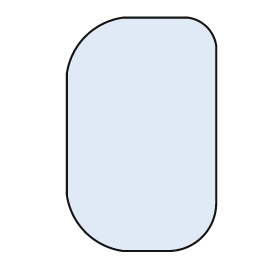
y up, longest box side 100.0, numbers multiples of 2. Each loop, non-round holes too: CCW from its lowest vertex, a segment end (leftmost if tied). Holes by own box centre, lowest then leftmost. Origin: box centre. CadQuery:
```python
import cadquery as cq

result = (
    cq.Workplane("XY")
    .moveTo(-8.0, -50.0)
    .lineTo(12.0, -50.0)
    .threePointArc((26.0, -44.0), (32.0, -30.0))
    .lineTo(32.0, 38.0)
    .threePointArc((28.0, 46.0), (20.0, 50.0))
    .lineTo(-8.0, 50.0)
    .threePointArc((-24.0, 42.0), (-32.0, 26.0))
    .lineTo(-32.0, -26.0)
    .threePointArc((-24.0, -42.0), (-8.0, -50.0))
    .close()
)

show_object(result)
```